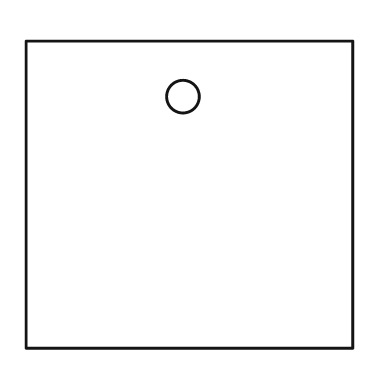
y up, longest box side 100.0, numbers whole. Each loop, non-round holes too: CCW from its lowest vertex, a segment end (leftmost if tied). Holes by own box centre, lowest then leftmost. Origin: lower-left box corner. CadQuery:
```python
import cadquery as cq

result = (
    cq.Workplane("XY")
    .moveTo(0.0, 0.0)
    .lineTo(100.0, 0.0)
    .lineTo(100.0, 94.0)
    .lineTo(0.0, 94.0)
    .close()
    .moveTo(48.0, 77.0)
    .circle(5.0)
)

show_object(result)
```